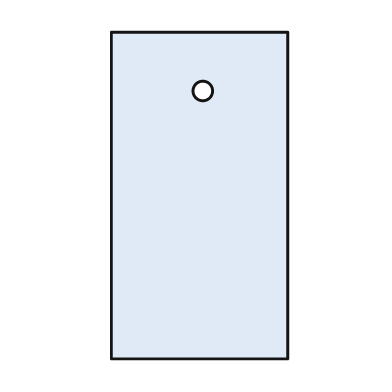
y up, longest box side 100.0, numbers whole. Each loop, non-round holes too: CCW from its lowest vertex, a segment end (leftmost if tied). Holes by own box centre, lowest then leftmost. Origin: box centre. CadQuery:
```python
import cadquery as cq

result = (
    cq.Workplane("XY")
    .moveTo(-27.0, -50.0)
    .lineTo(27.0, -50.0)
    .lineTo(27.0, 50.0)
    .lineTo(-27.0, 50.0)
    .close()
    .moveTo(1.0, 32.0)
    .circle(3.0)
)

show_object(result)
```